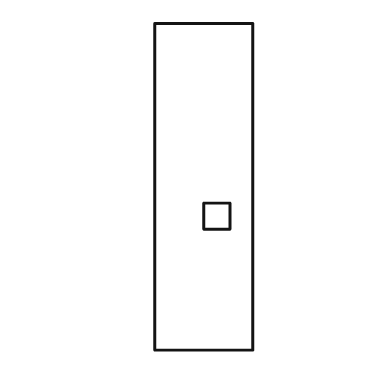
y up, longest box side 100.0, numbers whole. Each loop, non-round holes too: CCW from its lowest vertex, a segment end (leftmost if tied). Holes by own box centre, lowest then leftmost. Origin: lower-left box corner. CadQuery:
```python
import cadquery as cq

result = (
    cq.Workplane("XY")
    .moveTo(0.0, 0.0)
    .lineTo(30.0, 0.0)
    .lineTo(30.0, 100.0)
    .lineTo(0.0, 100.0)
    .close()
    .moveTo(15.0, 37.0)
    .lineTo(23.0, 37.0)
    .lineTo(23.0, 45.0)
    .lineTo(15.0, 45.0)
    .close()
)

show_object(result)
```